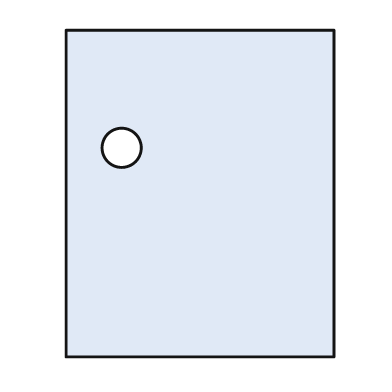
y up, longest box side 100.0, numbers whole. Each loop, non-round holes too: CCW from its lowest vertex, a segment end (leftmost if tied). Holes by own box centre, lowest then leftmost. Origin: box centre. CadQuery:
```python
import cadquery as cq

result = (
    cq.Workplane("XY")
    .moveTo(-41.0, -50.0)
    .lineTo(41.0, -50.0)
    .lineTo(41.0, 50.0)
    .lineTo(-41.0, 50.0)
    .close()
    .moveTo(-24.0, 14.0)
    .circle(6.0)
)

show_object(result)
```